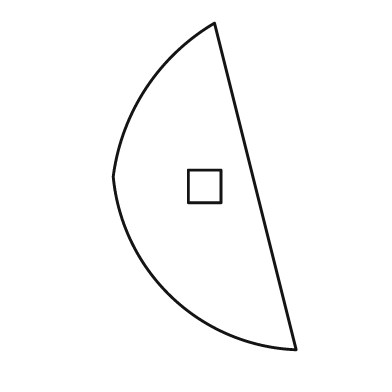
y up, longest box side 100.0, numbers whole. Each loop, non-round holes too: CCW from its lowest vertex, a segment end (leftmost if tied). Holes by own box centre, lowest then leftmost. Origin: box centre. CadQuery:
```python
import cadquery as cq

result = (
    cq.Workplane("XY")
    .moveTo(28.0, -50.0)
    .lineTo(3.0, 50.0)
    .threePointArc((-18.0, 30.0), (-28.0, 3.0))
    .threePointArc((-10.0, -34.0), (28.0, -50.0))
    .close()
    .moveTo(-5.0, -5.0)
    .lineTo(5.0, -5.0)
    .lineTo(5.0, 5.0)
    .lineTo(-5.0, 5.0)
    .close()
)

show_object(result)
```